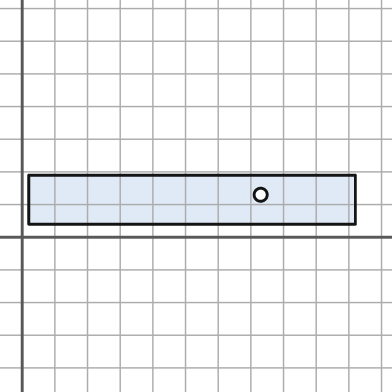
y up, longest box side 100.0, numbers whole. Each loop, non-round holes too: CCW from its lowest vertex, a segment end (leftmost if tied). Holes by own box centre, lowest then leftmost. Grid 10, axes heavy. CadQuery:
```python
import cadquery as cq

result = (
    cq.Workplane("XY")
    .moveTo(2.0, 4.0)
    .lineTo(102.0, 4.0)
    .lineTo(102.0, 19.0)
    .lineTo(2.0, 19.0)
    .close()
    .moveTo(73.0, 13.0)
    .circle(2.0)
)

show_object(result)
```